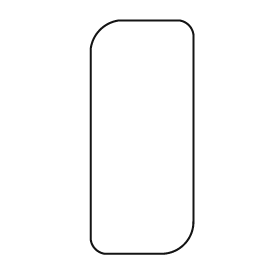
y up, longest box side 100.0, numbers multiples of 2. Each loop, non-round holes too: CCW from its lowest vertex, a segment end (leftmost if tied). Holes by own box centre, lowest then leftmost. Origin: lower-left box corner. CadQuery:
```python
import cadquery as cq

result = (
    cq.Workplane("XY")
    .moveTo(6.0, 0.0)
    .lineTo(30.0, 0.0)
    .threePointArc((40.0, 4.0), (44.0, 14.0))
    .lineTo(44.0, 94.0)
    .threePointArc((42.0, 98.0), (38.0, 100.0))
    .lineTo(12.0, 100.0)
    .threePointArc((4.0, 96.0), (0.0, 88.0))
    .lineTo(0.0, 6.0)
    .threePointArc((2.0, 2.0), (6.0, 0.0))
    .close()
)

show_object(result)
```